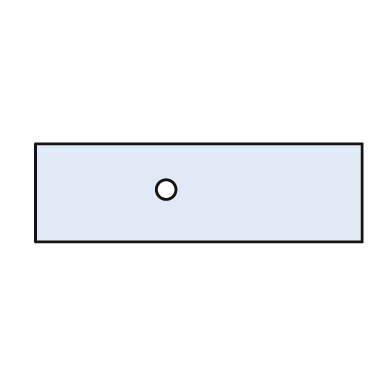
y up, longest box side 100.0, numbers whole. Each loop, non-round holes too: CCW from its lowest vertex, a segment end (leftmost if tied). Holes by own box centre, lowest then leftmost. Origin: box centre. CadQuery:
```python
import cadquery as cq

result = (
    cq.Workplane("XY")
    .moveTo(-50.0, -15.0)
    .lineTo(50.0, -15.0)
    .lineTo(50.0, 15.0)
    .lineTo(-50.0, 15.0)
    .close()
    .moveTo(-10.0, 1.0)
    .circle(3.0)
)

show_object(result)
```